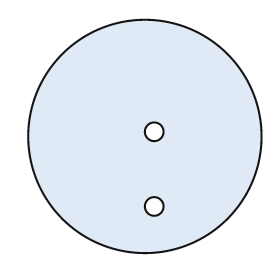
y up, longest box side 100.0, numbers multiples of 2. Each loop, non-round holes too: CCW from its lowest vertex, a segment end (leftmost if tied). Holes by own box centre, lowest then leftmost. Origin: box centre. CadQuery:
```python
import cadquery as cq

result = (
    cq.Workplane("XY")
    .moveTo(0.0, 0.0)
    .circle(50.0)
    .moveTo(4.0, -30.0)
    .circle(4.0)
    .moveTo(4.0, 2.0)
    .circle(4.0)
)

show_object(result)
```